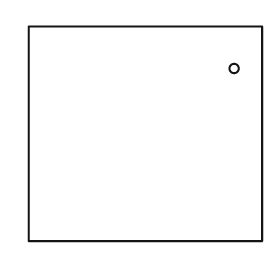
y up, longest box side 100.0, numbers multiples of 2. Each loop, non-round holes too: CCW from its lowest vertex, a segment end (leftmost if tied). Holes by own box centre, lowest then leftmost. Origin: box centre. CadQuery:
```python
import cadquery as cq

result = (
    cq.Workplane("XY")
    .moveTo(-50.0, -46.0)
    .lineTo(50.0, -46.0)
    .lineTo(50.0, 46.0)
    .lineTo(-50.0, 46.0)
    .close()
    .moveTo(38.0, 28.0)
    .circle(2.0)
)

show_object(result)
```